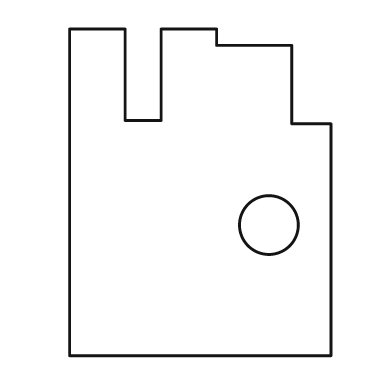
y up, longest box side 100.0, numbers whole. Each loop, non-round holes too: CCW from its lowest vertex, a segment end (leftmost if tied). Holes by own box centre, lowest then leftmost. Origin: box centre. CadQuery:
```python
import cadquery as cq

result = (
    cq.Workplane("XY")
    .moveTo(-40.0, -50.0)
    .lineTo(40.0, -50.0)
    .lineTo(40.0, 21.0)
    .lineTo(28.0, 21.0)
    .lineTo(28.0, 45.0)
    .lineTo(5.0, 45.0)
    .lineTo(5.0, 50.0)
    .lineTo(-12.0, 50.0)
    .lineTo(-12.0, 22.0)
    .lineTo(-23.0, 22.0)
    .lineTo(-23.0, 50.0)
    .lineTo(-40.0, 50.0)
    .close()
    .moveTo(21.0, -10.0)
    .circle(9.0)
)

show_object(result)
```